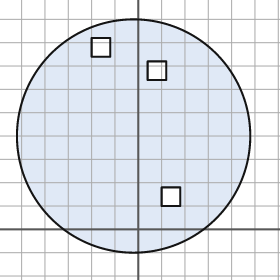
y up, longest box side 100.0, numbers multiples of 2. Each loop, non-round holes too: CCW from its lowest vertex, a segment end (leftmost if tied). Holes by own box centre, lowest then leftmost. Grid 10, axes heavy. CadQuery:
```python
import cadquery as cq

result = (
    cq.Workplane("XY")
    .moveTo(-2.0, 40.0)
    .circle(50.0)
    .moveTo(10.0, 10.0)
    .lineTo(18.0, 10.0)
    .lineTo(18.0, 18.0)
    .lineTo(10.0, 18.0)
    .close()
    .moveTo(4.0, 64.0)
    .lineTo(12.0, 64.0)
    .lineTo(12.0, 72.0)
    .lineTo(4.0, 72.0)
    .close()
    .moveTo(-20.0, 74.0)
    .lineTo(-12.0, 74.0)
    .lineTo(-12.0, 82.0)
    .lineTo(-20.0, 82.0)
    .close()
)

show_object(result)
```